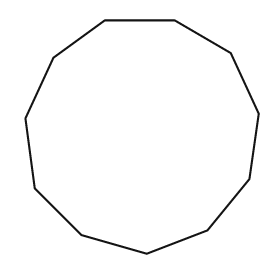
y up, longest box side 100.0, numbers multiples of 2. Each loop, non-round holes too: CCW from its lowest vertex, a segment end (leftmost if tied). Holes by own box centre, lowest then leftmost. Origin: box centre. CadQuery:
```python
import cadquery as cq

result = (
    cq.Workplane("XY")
    .moveTo(2.0, -50.0)
    .lineTo(28.0, -40.0)
    .lineTo(46.0, -18.0)
    .lineTo(50.0, 10.0)
    .lineTo(38.0, 36.0)
    .lineTo(14.0, 50.0)
    .lineTo(-16.0, 50.0)
    .lineTo(-38.0, 34.0)
    .lineTo(-50.0, 8.0)
    .lineTo(-46.0, -22.0)
    .lineTo(-26.0, -42.0)
    .close()
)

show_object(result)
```